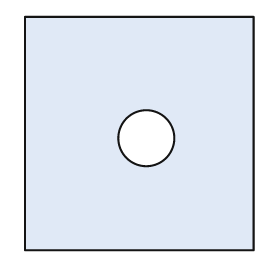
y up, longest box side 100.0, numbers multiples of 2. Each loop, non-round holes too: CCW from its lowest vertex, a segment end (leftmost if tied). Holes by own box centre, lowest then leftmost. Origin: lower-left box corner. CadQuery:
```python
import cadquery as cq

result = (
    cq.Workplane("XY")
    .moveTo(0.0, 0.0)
    .lineTo(98.0, 0.0)
    .lineTo(98.0, 100.0)
    .lineTo(0.0, 100.0)
    .close()
    .moveTo(52.0, 48.0)
    .circle(12.0)
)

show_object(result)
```